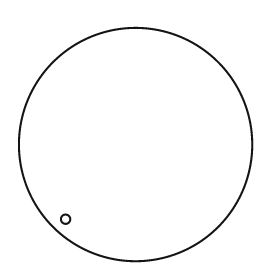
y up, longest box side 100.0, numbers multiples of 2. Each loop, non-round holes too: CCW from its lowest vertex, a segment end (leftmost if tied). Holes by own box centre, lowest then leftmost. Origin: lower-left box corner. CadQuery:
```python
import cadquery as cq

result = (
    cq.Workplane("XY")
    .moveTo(50.0, 50.0)
    .circle(50.0)
    .moveTo(20.0, 18.0)
    .circle(2.0)
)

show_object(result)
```